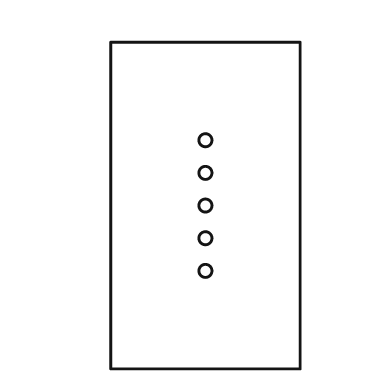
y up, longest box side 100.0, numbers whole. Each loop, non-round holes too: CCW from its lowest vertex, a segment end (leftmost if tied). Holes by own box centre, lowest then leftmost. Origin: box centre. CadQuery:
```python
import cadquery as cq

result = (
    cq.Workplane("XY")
    .moveTo(-29.0, -50.0)
    .lineTo(29.0, -50.0)
    .lineTo(29.0, 50.0)
    .lineTo(-29.0, 50.0)
    .close()
    .moveTo(0.0, -20.0)
    .circle(2.0)
    .moveTo(0.0, -10.0)
    .circle(2.0)
    .moveTo(0.0, 0.0)
    .circle(2.0)
    .moveTo(0.0, 10.0)
    .circle(2.0)
    .moveTo(0.0, 20.0)
    .circle(2.0)
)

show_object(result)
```